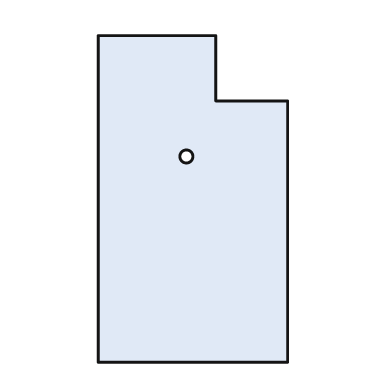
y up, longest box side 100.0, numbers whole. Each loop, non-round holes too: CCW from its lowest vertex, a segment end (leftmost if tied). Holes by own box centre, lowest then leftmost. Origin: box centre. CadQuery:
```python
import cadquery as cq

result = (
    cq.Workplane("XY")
    .moveTo(-29.0, -50.0)
    .lineTo(29.0, -50.0)
    .lineTo(29.0, 30.0)
    .lineTo(7.0, 30.0)
    .lineTo(7.0, 50.0)
    .lineTo(-29.0, 50.0)
    .close()
    .moveTo(-2.0, 13.0)
    .circle(2.0)
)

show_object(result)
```